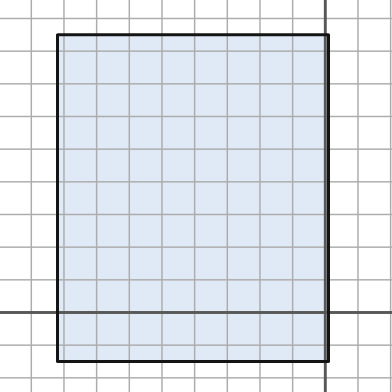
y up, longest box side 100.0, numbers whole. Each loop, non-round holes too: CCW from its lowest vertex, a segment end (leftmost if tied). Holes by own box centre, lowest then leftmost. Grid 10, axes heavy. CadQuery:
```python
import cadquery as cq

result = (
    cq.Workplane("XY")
    .moveTo(-82.0, -15.0)
    .lineTo(1.0, -15.0)
    .lineTo(1.0, 85.0)
    .lineTo(-82.0, 85.0)
    .close()
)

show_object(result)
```